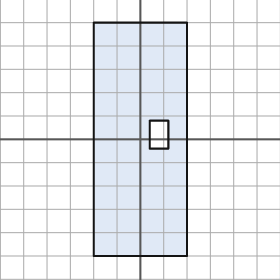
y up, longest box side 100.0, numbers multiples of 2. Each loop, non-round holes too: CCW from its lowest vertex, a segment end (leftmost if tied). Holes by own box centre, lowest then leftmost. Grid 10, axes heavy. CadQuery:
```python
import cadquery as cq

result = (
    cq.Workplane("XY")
    .moveTo(-20.0, -50.0)
    .lineTo(20.0, -50.0)
    .lineTo(20.0, 50.0)
    .lineTo(-20.0, 50.0)
    .close()
    .moveTo(4.0, -4.0)
    .lineTo(12.0, -4.0)
    .lineTo(12.0, 8.0)
    .lineTo(4.0, 8.0)
    .close()
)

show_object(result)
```